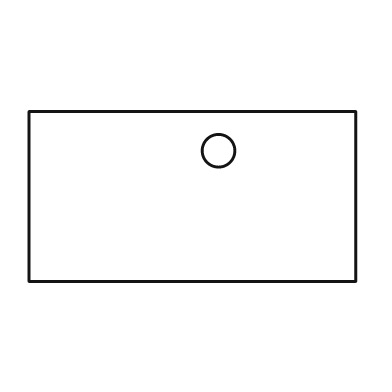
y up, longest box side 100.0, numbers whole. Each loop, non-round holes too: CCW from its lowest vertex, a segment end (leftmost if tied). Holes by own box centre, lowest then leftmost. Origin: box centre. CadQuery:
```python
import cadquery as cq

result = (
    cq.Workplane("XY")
    .moveTo(-50.0, -26.0)
    .lineTo(50.0, -26.0)
    .lineTo(50.0, 26.0)
    .lineTo(-50.0, 26.0)
    .close()
    .moveTo(8.0, 14.0)
    .circle(5.0)
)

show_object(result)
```